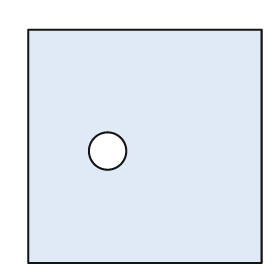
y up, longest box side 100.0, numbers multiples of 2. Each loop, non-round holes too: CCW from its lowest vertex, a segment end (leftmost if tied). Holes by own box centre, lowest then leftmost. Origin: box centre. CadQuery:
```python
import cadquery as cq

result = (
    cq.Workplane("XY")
    .moveTo(-50.0, -50.0)
    .lineTo(50.0, -50.0)
    .lineTo(50.0, 50.0)
    .lineTo(-50.0, 50.0)
    .close()
    .moveTo(-16.0, -2.0)
    .circle(8.0)
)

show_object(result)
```